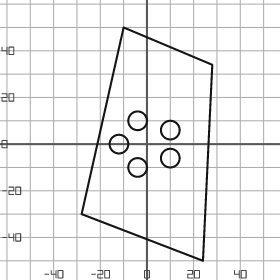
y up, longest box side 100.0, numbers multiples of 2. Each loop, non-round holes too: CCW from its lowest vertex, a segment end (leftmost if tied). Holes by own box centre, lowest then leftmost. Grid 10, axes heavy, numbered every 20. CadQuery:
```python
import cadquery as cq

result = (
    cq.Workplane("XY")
    .moveTo(24.0, -50.0)
    .lineTo(28.0, 34.0)
    .lineTo(-10.0, 50.0)
    .lineTo(-28.0, -30.0)
    .close()
    .moveTo(-4.0, -10.0)
    .circle(4.0)
    .moveTo(10.0, -6.0)
    .circle(4.0)
    .moveTo(-12.0, 0.0)
    .circle(4.0)
    .moveTo(10.0, 6.0)
    .circle(4.0)
    .moveTo(-4.0, 10.0)
    .circle(4.0)
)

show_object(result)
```